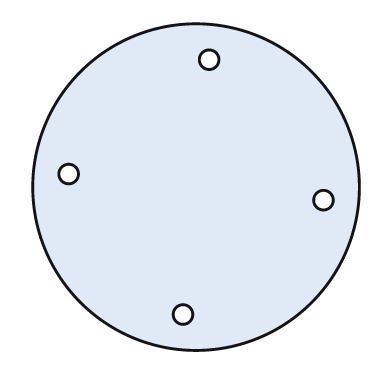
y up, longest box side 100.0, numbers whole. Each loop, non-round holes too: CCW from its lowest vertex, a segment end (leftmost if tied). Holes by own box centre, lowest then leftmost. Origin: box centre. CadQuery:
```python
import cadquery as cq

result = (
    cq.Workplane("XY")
    .moveTo(0.0, 0.0)
    .circle(50.0)
    .moveTo(-4.0, -39.0)
    .circle(3.0)
    .moveTo(39.0, -4.0)
    .circle(3.0)
    .moveTo(-39.0, 4.0)
    .circle(3.0)
    .moveTo(4.0, 39.0)
    .circle(3.0)
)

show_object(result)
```